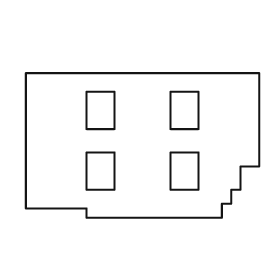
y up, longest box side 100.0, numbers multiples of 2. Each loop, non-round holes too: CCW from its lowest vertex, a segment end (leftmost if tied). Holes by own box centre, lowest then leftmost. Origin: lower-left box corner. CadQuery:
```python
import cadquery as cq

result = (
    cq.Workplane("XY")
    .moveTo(26.0, 0.0)
    .lineTo(84.0, 0.0)
    .lineTo(84.0, 6.0)
    .lineTo(88.0, 6.0)
    .lineTo(88.0, 12.0)
    .lineTo(92.0, 12.0)
    .lineTo(92.0, 22.0)
    .lineTo(100.0, 22.0)
    .lineTo(100.0, 62.0)
    .lineTo(0.0, 62.0)
    .lineTo(0.0, 4.0)
    .lineTo(26.0, 4.0)
    .close()
    .moveTo(26.0, 12.0)
    .lineTo(38.0, 12.0)
    .lineTo(38.0, 28.0)
    .lineTo(26.0, 28.0)
    .close()
    .moveTo(62.0, 12.0)
    .lineTo(74.0, 12.0)
    .lineTo(74.0, 28.0)
    .lineTo(62.0, 28.0)
    .close()
    .moveTo(26.0, 38.0)
    .lineTo(38.0, 38.0)
    .lineTo(38.0, 54.0)
    .lineTo(26.0, 54.0)
    .close()
    .moveTo(62.0, 38.0)
    .lineTo(74.0, 38.0)
    .lineTo(74.0, 54.0)
    .lineTo(62.0, 54.0)
    .close()
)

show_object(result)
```